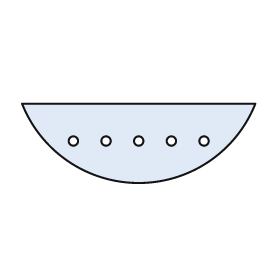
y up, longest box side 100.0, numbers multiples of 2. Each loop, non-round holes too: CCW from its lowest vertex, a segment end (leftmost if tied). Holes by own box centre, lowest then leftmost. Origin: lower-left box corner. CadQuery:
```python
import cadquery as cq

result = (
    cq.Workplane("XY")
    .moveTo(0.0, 34.0)
    .threePointArc((50.0, 0.0), (100.0, 34.0))
    .close()
    .moveTo(22.0, 18.0)
    .circle(2.0)
    .moveTo(36.0, 18.0)
    .circle(2.0)
    .moveTo(50.0, 18.0)
    .circle(2.0)
    .moveTo(64.0, 18.0)
    .circle(2.0)
    .moveTo(78.0, 18.0)
    .circle(2.0)
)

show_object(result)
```